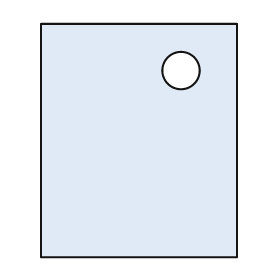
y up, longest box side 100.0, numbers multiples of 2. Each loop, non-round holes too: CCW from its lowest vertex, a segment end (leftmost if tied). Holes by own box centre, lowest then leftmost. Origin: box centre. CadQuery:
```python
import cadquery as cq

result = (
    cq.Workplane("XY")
    .moveTo(-42.0, -50.0)
    .lineTo(42.0, -50.0)
    .lineTo(42.0, 50.0)
    .lineTo(-42.0, 50.0)
    .close()
    .moveTo(18.0, 30.0)
    .circle(8.0)
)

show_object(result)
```